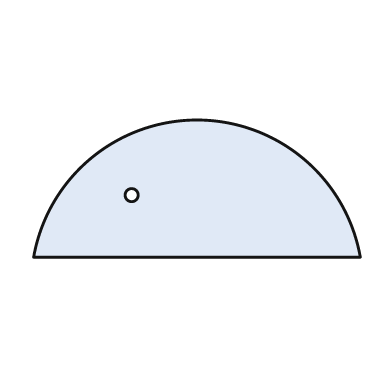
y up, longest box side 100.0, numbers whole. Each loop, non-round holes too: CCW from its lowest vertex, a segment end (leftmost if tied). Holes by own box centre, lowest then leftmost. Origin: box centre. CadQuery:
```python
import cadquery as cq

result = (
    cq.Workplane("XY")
    .moveTo(-50.0, -21.0)
    .lineTo(50.0, -21.0)
    .threePointArc((0.0, 21.0), (-50.0, -21.0))
    .close()
    .moveTo(-20.0, -2.0)
    .circle(2.0)
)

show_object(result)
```